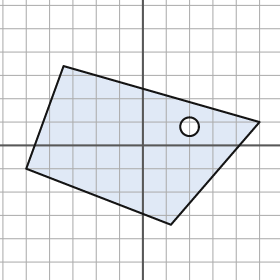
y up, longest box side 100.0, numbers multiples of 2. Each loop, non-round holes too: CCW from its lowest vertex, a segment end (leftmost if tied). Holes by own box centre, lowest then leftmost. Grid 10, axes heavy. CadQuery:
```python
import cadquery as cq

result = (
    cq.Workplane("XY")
    .moveTo(12.0, -34.0)
    .lineTo(50.0, 10.0)
    .lineTo(-34.0, 34.0)
    .lineTo(-50.0, -10.0)
    .close()
    .moveTo(20.0, 8.0)
    .circle(4.0)
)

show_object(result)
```